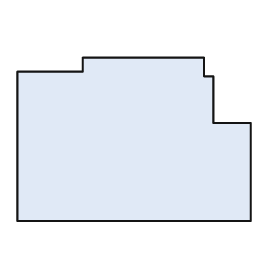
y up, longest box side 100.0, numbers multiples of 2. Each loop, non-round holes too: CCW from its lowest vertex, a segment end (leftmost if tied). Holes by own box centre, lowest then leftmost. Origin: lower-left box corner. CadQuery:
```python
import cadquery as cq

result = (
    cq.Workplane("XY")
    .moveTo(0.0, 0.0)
    .lineTo(100.0, 0.0)
    .lineTo(100.0, 42.0)
    .lineTo(84.0, 42.0)
    .lineTo(84.0, 62.0)
    .lineTo(80.0, 62.0)
    .lineTo(80.0, 70.0)
    .lineTo(28.0, 70.0)
    .lineTo(28.0, 64.0)
    .lineTo(0.0, 64.0)
    .close()
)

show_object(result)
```